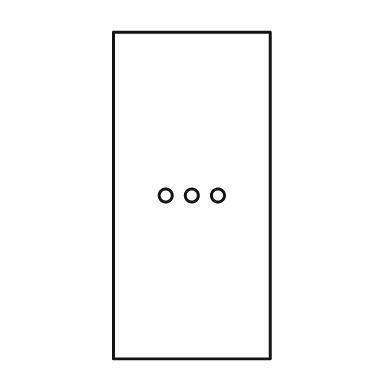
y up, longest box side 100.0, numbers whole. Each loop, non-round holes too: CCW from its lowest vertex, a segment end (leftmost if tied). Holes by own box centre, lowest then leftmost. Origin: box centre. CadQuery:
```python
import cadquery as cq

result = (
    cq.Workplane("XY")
    .moveTo(-24.0, -50.0)
    .lineTo(24.0, -50.0)
    .lineTo(24.0, 50.0)
    .lineTo(-24.0, 50.0)
    .close()
    .moveTo(-8.0, 0.0)
    .circle(2.0)
    .moveTo(0.0, 0.0)
    .circle(2.0)
    .moveTo(8.0, 0.0)
    .circle(2.0)
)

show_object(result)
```